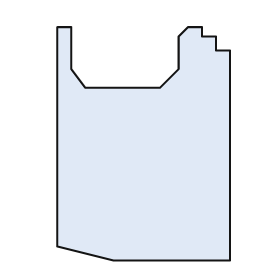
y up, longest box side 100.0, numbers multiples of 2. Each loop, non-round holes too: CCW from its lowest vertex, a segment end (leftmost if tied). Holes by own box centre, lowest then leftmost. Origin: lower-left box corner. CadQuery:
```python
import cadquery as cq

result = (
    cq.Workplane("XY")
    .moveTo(24.0, 0.0)
    .lineTo(74.0, 0.0)
    .lineTo(74.0, 90.0)
    .lineTo(68.0, 90.0)
    .lineTo(68.0, 96.0)
    .lineTo(62.0, 96.0)
    .lineTo(62.0, 100.0)
    .lineTo(56.0, 100.0)
    .lineTo(52.0, 96.0)
    .lineTo(52.0, 82.0)
    .lineTo(44.0, 74.0)
    .lineTo(12.0, 74.0)
    .lineTo(6.0, 82.0)
    .lineTo(6.0, 100.0)
    .lineTo(0.0, 100.0)
    .lineTo(0.0, 6.0)
    .close()
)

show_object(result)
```